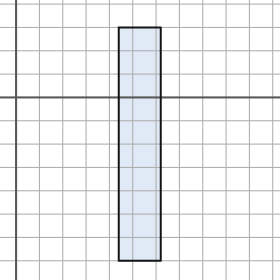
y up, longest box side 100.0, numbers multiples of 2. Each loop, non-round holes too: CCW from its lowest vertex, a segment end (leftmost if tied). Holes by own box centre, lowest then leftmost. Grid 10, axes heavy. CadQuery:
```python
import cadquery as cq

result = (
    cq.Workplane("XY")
    .moveTo(44.0, -70.0)
    .lineTo(62.0, -70.0)
    .lineTo(62.0, 30.0)
    .lineTo(44.0, 30.0)
    .close()
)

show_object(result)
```